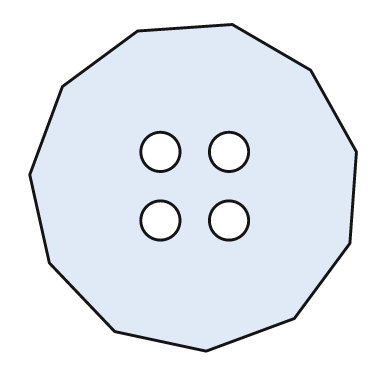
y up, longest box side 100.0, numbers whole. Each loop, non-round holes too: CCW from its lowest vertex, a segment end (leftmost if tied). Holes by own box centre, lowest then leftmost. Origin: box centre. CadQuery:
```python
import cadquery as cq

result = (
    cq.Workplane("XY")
    .moveTo(4.0, -50.0)
    .lineTo(31.0, -40.0)
    .lineTo(48.0, -17.0)
    .lineTo(50.0, 11.0)
    .lineTo(36.0, 36.0)
    .lineTo(12.0, 50.0)
    .lineTo(-17.0, 48.0)
    .lineTo(-40.0, 31.0)
    .lineTo(-50.0, 4.0)
    .lineTo(-44.0, -23.0)
    .lineTo(-24.0, -44.0)
    .close()
    .moveTo(-10.0, -10.0)
    .circle(6.0)
    .moveTo(11.0, -10.0)
    .circle(6.0)
    .moveTo(-10.0, 11.0)
    .circle(6.0)
    .moveTo(11.0, 11.0)
    .circle(6.0)
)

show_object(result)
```